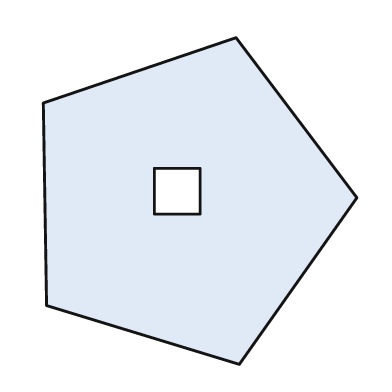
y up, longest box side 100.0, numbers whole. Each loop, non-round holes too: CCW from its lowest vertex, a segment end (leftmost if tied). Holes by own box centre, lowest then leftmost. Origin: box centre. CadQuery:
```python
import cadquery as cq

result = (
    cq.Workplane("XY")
    .moveTo(12.0, -50.0)
    .lineTo(48.0, 1.0)
    .lineTo(11.0, 50.0)
    .lineTo(-48.0, 30.0)
    .lineTo(-47.0, -32.0)
    .close()
    .moveTo(-14.0, -4.0)
    .lineTo(0.0, -4.0)
    .lineTo(0.0, 10.0)
    .lineTo(-14.0, 10.0)
    .close()
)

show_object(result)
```